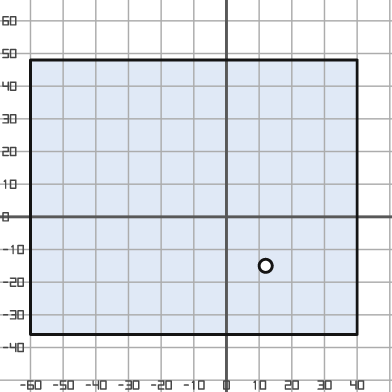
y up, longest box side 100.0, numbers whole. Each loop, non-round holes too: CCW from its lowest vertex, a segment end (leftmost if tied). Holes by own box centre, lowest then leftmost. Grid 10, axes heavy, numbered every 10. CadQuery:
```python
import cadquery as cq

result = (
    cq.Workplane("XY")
    .moveTo(-60.0, -36.0)
    .lineTo(40.0, -36.0)
    .lineTo(40.0, 48.0)
    .lineTo(-60.0, 48.0)
    .close()
    .moveTo(12.0, -15.0)
    .circle(2.0)
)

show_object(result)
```